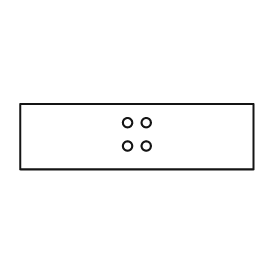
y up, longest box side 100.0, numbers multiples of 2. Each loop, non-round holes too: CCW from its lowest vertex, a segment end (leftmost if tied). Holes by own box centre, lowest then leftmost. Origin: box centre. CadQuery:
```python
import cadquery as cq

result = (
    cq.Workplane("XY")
    .moveTo(-50.0, -14.0)
    .lineTo(50.0, -14.0)
    .lineTo(50.0, 14.0)
    .lineTo(-50.0, 14.0)
    .close()
    .moveTo(-4.0, -4.0)
    .circle(2.0)
    .moveTo(4.0, -4.0)
    .circle(2.0)
    .moveTo(-4.0, 6.0)
    .circle(2.0)
    .moveTo(4.0, 6.0)
    .circle(2.0)
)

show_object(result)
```